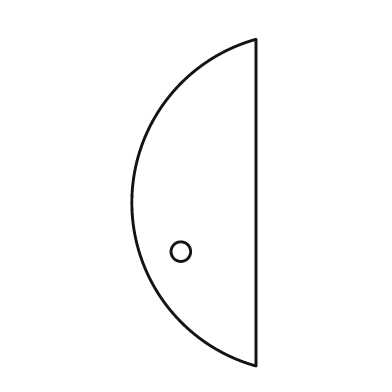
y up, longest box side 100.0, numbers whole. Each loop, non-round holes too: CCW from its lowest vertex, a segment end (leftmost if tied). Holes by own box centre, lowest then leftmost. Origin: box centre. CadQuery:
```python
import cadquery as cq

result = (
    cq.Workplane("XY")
    .moveTo(19.0, -50.0)
    .lineTo(19.0, 50.0)
    .threePointArc((-19.0, 0.0), (19.0, -50.0))
    .close()
    .moveTo(-4.0, -15.0)
    .circle(3.0)
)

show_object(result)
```